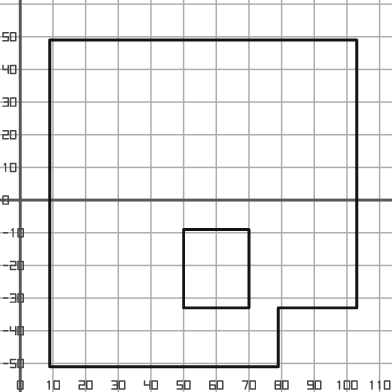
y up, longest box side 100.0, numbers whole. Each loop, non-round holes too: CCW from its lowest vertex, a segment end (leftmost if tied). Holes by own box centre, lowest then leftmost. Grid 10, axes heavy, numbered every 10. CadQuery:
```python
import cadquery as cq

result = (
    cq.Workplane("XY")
    .moveTo(9.0, -51.0)
    .lineTo(79.0, -51.0)
    .lineTo(79.0, -33.0)
    .lineTo(103.0, -33.0)
    .lineTo(103.0, 49.0)
    .lineTo(9.0, 49.0)
    .close()
    .moveTo(50.0, -33.0)
    .lineTo(70.0, -33.0)
    .lineTo(70.0, -9.0)
    .lineTo(50.0, -9.0)
    .close()
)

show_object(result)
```